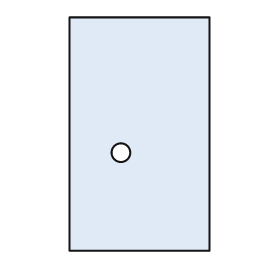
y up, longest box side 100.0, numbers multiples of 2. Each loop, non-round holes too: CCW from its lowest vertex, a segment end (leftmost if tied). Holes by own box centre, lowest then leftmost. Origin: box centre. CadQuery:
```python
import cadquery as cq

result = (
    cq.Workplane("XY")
    .moveTo(-30.0, -50.0)
    .lineTo(30.0, -50.0)
    .lineTo(30.0, 50.0)
    .lineTo(-30.0, 50.0)
    .close()
    .moveTo(-8.0, -8.0)
    .circle(4.0)
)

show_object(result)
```